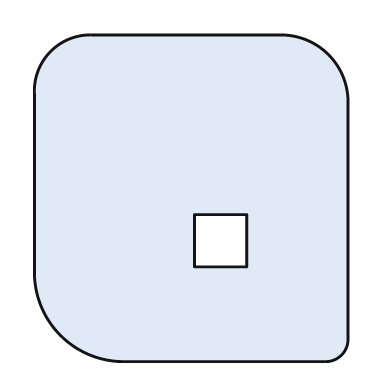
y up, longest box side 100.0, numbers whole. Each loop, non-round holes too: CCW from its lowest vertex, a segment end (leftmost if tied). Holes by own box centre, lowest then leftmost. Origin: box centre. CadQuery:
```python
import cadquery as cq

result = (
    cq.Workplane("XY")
    .moveTo(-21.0, -50.0)
    .lineTo(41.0, -50.0)
    .threePointArc((46.0, -48.0), (48.0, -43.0))
    .lineTo(48.0, 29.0)
    .threePointArc((42.0, 44.0), (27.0, 50.0))
    .lineTo(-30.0, 50.0)
    .threePointArc((-43.0, 45.0), (-48.0, 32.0))
    .lineTo(-48.0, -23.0)
    .threePointArc((-40.0, -42.0), (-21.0, -50.0))
    .close()
    .moveTo(1.0, -21.0)
    .lineTo(17.0, -21.0)
    .lineTo(17.0, -5.0)
    .lineTo(1.0, -5.0)
    .close()
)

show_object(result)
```